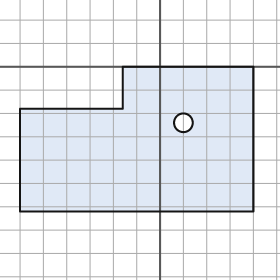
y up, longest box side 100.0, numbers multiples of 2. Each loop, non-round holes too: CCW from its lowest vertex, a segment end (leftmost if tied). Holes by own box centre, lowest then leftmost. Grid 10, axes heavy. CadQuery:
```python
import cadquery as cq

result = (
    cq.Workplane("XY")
    .moveTo(-60.0, -62.0)
    .lineTo(40.0, -62.0)
    .lineTo(40.0, 0.0)
    .lineTo(-16.0, 0.0)
    .lineTo(-16.0, -18.0)
    .lineTo(-60.0, -18.0)
    .close()
    .moveTo(10.0, -24.0)
    .circle(4.0)
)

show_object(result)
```